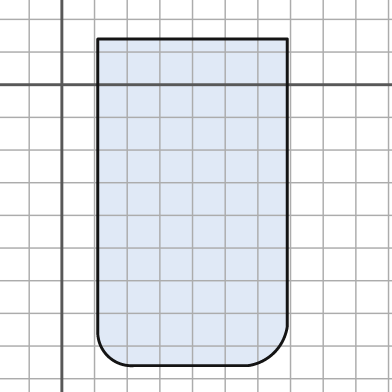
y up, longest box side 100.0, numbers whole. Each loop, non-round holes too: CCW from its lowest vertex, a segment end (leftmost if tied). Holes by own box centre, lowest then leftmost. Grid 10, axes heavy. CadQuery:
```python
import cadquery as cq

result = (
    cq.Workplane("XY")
    .moveTo(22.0, -86.0)
    .lineTo(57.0, -86.0)
    .threePointArc((65.0, -82.0), (69.0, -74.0))
    .lineTo(69.0, 14.0)
    .lineTo(11.0, 14.0)
    .lineTo(11.0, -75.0)
    .threePointArc((14.0, -83.0), (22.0, -86.0))
    .close()
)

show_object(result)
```